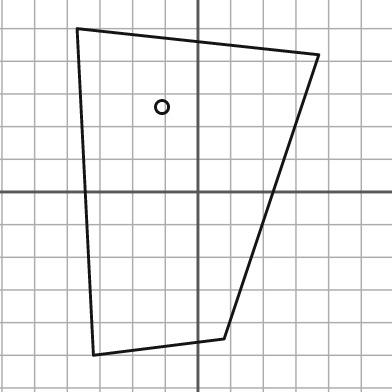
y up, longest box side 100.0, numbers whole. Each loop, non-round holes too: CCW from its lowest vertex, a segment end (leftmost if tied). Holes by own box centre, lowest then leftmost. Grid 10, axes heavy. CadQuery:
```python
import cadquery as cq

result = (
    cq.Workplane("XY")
    .moveTo(-32.0, -50.0)
    .lineTo(8.0, -45.0)
    .lineTo(37.0, 42.0)
    .lineTo(-37.0, 50.0)
    .close()
    .moveTo(-11.0, 26.0)
    .circle(2.0)
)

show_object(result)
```